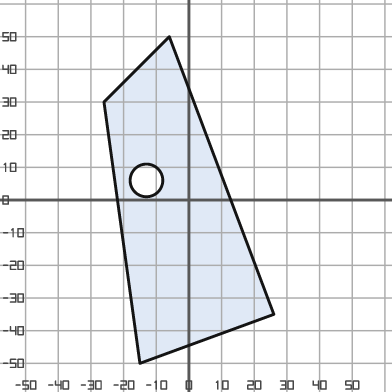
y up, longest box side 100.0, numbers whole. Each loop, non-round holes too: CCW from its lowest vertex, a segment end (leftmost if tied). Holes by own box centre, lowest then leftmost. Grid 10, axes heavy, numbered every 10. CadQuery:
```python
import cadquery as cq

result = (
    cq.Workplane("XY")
    .moveTo(-15.0, -50.0)
    .lineTo(26.0, -35.0)
    .lineTo(-6.0, 50.0)
    .lineTo(-26.0, 30.0)
    .close()
    .moveTo(-13.0, 6.0)
    .circle(5.0)
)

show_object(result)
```